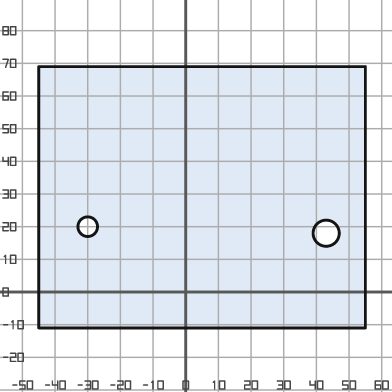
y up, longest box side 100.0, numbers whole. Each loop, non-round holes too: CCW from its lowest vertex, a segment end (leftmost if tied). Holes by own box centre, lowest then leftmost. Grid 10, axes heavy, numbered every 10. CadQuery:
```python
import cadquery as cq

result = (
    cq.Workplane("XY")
    .moveTo(-45.0, -11.0)
    .lineTo(55.0, -11.0)
    .lineTo(55.0, 69.0)
    .lineTo(-45.0, 69.0)
    .close()
    .moveTo(43.0, 18.0)
    .circle(4.0)
    .moveTo(-30.0, 20.0)
    .circle(3.0)
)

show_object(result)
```